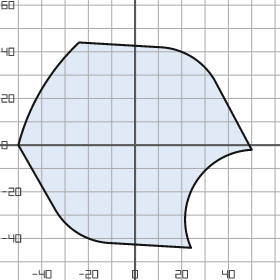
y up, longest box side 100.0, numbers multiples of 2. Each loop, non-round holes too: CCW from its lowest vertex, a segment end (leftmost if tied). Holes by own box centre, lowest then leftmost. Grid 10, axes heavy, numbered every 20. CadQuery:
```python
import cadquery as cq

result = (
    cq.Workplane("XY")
    .moveTo(24.0, -44.0)
    .threePointArc((26.0, -16.0), (50.0, -2.0))
    .lineTo(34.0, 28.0)
    .threePointArc((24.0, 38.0), (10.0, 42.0))
    .lineTo(-24.0, 44.0)
    .threePointArc((-40.0, 24.0), (-50.0, 0.0))
    .lineTo(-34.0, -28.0)
    .threePointArc((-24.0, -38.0), (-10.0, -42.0))
    .close()
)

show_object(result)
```